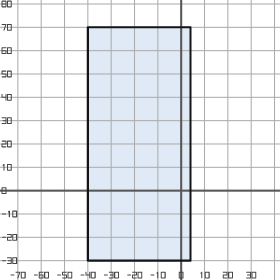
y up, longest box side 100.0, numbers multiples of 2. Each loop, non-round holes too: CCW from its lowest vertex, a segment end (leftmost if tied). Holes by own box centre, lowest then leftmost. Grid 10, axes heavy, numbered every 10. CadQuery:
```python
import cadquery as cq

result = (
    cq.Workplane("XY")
    .moveTo(-40.0, -30.0)
    .lineTo(4.0, -30.0)
    .lineTo(4.0, 70.0)
    .lineTo(-40.0, 70.0)
    .close()
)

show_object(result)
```